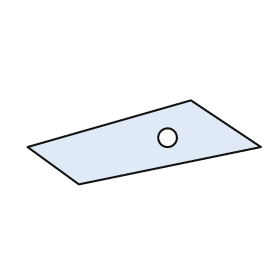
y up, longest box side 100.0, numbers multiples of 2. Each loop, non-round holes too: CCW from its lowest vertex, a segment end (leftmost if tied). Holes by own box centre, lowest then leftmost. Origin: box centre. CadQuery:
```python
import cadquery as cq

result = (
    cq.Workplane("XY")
    .moveTo(-28.0, -18.0)
    .lineTo(50.0, -2.0)
    .lineTo(20.0, 18.0)
    .lineTo(-50.0, -2.0)
    .close()
    .moveTo(10.0, 2.0)
    .circle(4.0)
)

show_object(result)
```